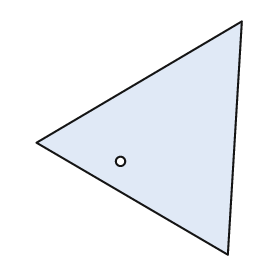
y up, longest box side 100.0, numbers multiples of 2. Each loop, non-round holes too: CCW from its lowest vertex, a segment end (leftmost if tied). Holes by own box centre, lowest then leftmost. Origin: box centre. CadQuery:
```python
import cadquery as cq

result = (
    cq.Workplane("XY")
    .moveTo(38.0, -50.0)
    .lineTo(44.0, 50.0)
    .lineTo(-44.0, -2.0)
    .close()
    .moveTo(-8.0, -10.0)
    .circle(2.0)
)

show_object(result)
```